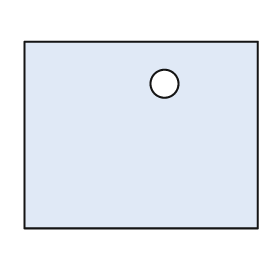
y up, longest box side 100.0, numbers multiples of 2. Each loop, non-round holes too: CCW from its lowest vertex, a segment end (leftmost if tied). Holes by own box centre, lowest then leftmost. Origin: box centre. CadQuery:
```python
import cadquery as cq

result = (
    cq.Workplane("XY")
    .moveTo(-50.0, -40.0)
    .lineTo(50.0, -40.0)
    .lineTo(50.0, 40.0)
    .lineTo(-50.0, 40.0)
    .close()
    .moveTo(10.0, 22.0)
    .circle(6.0)
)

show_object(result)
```